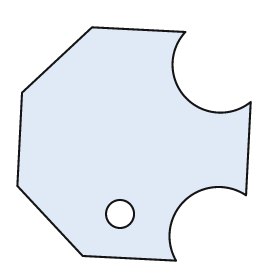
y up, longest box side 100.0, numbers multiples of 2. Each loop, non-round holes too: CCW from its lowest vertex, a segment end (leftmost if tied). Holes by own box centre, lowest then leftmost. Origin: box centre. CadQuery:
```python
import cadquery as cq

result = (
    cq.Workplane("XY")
    .moveTo(18.0, -50.0)
    .threePointArc((22.0, -24.0), (48.0, -22.0))
    .lineTo(50.0, 18.0)
    .threePointArc((22.0, 20.0), (22.0, 48.0))
    .lineTo(-18.0, 50.0)
    .lineTo(-48.0, 22.0)
    .lineTo(-50.0, -18.0)
    .lineTo(-22.0, -48.0)
    .close()
    .moveTo(-6.0, -30.0)
    .circle(6.0)
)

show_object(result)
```